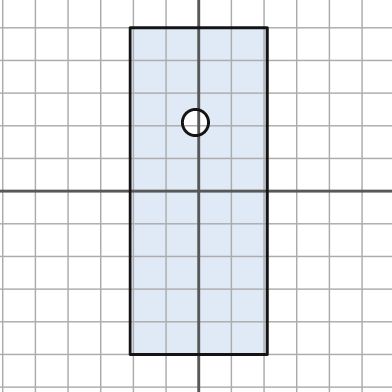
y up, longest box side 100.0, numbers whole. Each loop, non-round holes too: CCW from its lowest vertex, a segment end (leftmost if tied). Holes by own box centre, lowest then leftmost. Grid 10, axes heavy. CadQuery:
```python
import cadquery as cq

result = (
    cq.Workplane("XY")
    .moveTo(-21.0, -50.0)
    .lineTo(21.0, -50.0)
    .lineTo(21.0, 50.0)
    .lineTo(-21.0, 50.0)
    .close()
    .moveTo(-1.0, 21.0)
    .circle(4.0)
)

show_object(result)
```